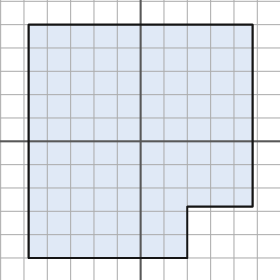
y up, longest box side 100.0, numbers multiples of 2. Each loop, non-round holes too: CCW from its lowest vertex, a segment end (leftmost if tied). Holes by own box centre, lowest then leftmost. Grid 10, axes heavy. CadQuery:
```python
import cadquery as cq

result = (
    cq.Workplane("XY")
    .moveTo(-48.0, -50.0)
    .lineTo(20.0, -50.0)
    .lineTo(20.0, -28.0)
    .lineTo(48.0, -28.0)
    .lineTo(48.0, 50.0)
    .lineTo(-48.0, 50.0)
    .close()
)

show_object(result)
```